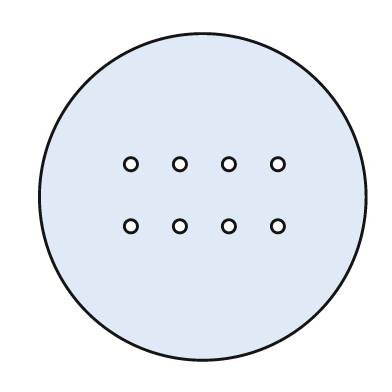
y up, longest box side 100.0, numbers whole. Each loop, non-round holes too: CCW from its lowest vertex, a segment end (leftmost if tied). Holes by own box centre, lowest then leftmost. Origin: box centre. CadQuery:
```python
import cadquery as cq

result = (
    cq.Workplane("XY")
    .moveTo(0.0, 0.0)
    .circle(50.0)
    .moveTo(-22.0, -9.0)
    .circle(2.0)
    .moveTo(-7.0, -9.0)
    .circle(2.0)
    .moveTo(8.0, -9.0)
    .circle(2.0)
    .moveTo(23.0, -9.0)
    .circle(2.0)
    .moveTo(-22.0, 10.0)
    .circle(2.0)
    .moveTo(-7.0, 10.0)
    .circle(2.0)
    .moveTo(8.0, 10.0)
    .circle(2.0)
    .moveTo(23.0, 10.0)
    .circle(2.0)
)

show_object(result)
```